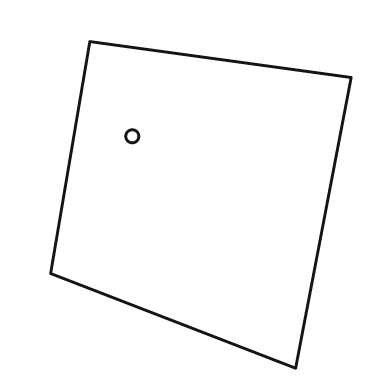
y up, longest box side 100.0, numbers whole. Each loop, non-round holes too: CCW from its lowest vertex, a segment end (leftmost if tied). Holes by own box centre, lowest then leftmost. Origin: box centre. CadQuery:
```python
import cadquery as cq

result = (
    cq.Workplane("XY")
    .moveTo(29.0, -50.0)
    .lineTo(46.0, 39.0)
    .lineTo(-34.0, 50.0)
    .lineTo(-46.0, -21.0)
    .close()
    .moveTo(-21.0, 21.0)
    .circle(2.0)
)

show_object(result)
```